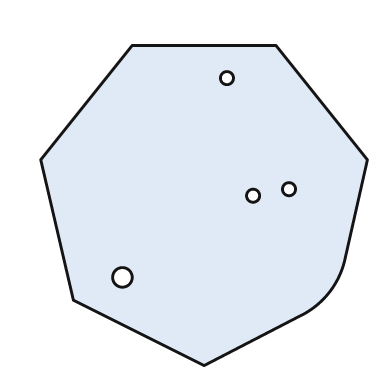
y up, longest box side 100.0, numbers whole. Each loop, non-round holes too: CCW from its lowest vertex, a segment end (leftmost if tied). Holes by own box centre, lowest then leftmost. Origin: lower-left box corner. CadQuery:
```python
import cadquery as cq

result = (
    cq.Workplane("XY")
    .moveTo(50.0, 0.0)
    .lineTo(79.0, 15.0)
    .threePointArc((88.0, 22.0), (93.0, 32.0))
    .lineTo(100.0, 63.0)
    .lineTo(72.0, 98.0)
    .lineTo(28.0, 98.0)
    .lineTo(0.0, 63.0)
    .lineTo(10.0, 20.0)
    .close()
    .moveTo(25.0, 27.0)
    .circle(3.0)
    .moveTo(65.0, 52.0)
    .circle(2.0)
    .moveTo(76.0, 54.0)
    .circle(2.0)
    .moveTo(57.0, 88.0)
    .circle(2.0)
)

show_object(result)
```